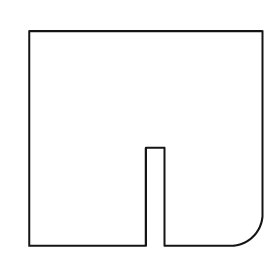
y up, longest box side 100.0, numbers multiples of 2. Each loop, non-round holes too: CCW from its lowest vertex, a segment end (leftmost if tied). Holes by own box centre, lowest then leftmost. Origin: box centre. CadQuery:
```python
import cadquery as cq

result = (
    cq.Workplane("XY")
    .moveTo(-50.0, -46.0)
    .lineTo(0.0, -46.0)
    .lineTo(0.0, -4.0)
    .lineTo(8.0, -4.0)
    .lineTo(8.0, -46.0)
    .lineTo(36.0, -46.0)
    .threePointArc((46.0, -42.0), (50.0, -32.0))
    .lineTo(50.0, 46.0)
    .lineTo(-50.0, 46.0)
    .close()
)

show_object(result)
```